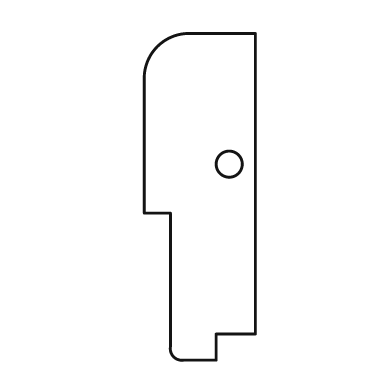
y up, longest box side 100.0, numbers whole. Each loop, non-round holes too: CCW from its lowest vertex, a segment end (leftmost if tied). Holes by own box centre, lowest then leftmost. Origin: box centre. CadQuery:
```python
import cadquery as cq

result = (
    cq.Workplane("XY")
    .moveTo(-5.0, -50.0)
    .lineTo(5.0, -50.0)
    .lineTo(5.0, -42.0)
    .lineTo(17.0, -42.0)
    .lineTo(17.0, 50.0)
    .lineTo(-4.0, 50.0)
    .threePointArc((-13.0, 46.0), (-17.0, 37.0))
    .lineTo(-17.0, -5.0)
    .lineTo(-9.0, -5.0)
    .lineTo(-9.0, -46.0)
    .threePointArc((-8.0, -49.0), (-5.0, -50.0))
    .close()
    .moveTo(9.0, 10.0)
    .circle(4.0)
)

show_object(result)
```